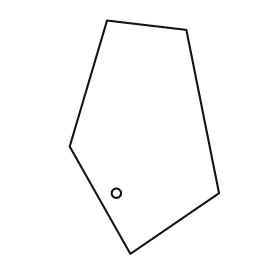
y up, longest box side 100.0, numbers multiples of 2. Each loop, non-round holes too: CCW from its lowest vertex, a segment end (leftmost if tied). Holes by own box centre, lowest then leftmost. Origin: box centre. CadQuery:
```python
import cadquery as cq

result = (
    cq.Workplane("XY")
    .moveTo(-6.0, -50.0)
    .lineTo(32.0, -24.0)
    .lineTo(18.0, 46.0)
    .lineTo(-16.0, 50.0)
    .lineTo(-32.0, -4.0)
    .close()
    .moveTo(-12.0, -24.0)
    .circle(2.0)
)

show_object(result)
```